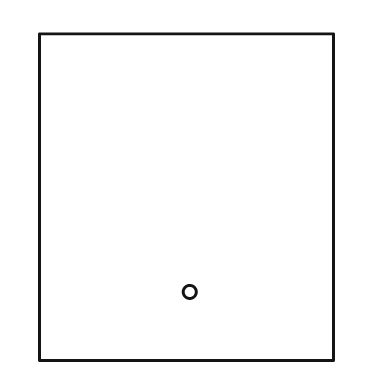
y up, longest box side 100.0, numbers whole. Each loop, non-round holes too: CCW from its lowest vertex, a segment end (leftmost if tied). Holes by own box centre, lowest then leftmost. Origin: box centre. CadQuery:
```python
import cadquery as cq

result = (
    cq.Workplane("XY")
    .moveTo(-45.0, -50.0)
    .lineTo(45.0, -50.0)
    .lineTo(45.0, 50.0)
    .lineTo(-45.0, 50.0)
    .close()
    .moveTo(1.0, -29.0)
    .circle(2.0)
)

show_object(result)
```